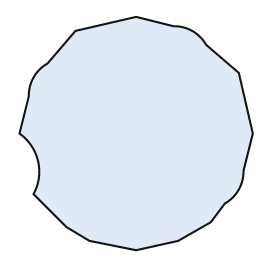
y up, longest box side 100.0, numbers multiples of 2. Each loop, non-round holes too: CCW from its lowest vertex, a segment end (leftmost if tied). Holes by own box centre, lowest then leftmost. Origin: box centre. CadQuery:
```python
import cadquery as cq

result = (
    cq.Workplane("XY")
    .moveTo(0.0, -50.0)
    .lineTo(18.0, -46.0)
    .lineTo(32.0, -38.0)
    .lineTo(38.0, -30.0)
    .threePointArc((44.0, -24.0), (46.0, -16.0))
    .lineTo(50.0, 0.0)
    .lineTo(44.0, 26.0)
    .lineTo(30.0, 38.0)
    .threePointArc((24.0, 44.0), (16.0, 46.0))
    .lineTo(0.0, 50.0)
    .lineTo(-26.0, 44.0)
    .lineTo(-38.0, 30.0)
    .threePointArc((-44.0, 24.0), (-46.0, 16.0))
    .lineTo(-50.0, 0.0)
    .threePointArc((-42.0, -12.0), (-44.0, -26.0))
    .lineTo(-30.0, -40.0)
    .lineTo(-20.0, -46.0)
    .close()
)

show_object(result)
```